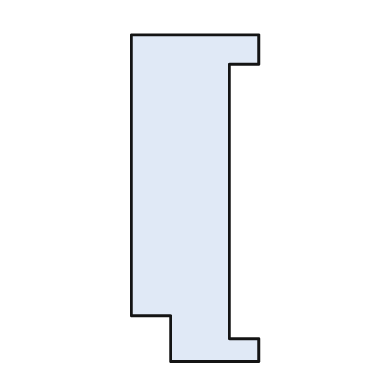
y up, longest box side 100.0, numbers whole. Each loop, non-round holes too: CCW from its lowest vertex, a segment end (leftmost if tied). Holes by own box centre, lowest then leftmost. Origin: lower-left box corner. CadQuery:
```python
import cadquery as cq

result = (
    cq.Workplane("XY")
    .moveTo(12.0, 0.0)
    .lineTo(39.0, 0.0)
    .lineTo(39.0, 7.0)
    .lineTo(30.0, 7.0)
    .lineTo(30.0, 91.0)
    .lineTo(39.0, 91.0)
    .lineTo(39.0, 100.0)
    .lineTo(0.0, 100.0)
    .lineTo(0.0, 14.0)
    .lineTo(12.0, 14.0)
    .close()
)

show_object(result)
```